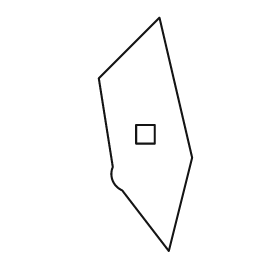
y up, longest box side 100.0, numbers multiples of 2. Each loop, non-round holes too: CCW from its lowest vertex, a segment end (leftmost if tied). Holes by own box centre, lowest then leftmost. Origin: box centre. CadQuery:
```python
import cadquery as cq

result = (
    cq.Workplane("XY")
    .moveTo(10.0, -50.0)
    .lineTo(20.0, -10.0)
    .lineTo(6.0, 50.0)
    .lineTo(-20.0, 24.0)
    .lineTo(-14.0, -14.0)
    .threePointArc((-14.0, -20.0), (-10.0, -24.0))
    .close()
    .moveTo(-4.0, -4.0)
    .lineTo(4.0, -4.0)
    .lineTo(4.0, 4.0)
    .lineTo(-4.0, 4.0)
    .close()
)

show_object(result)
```